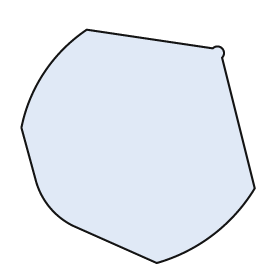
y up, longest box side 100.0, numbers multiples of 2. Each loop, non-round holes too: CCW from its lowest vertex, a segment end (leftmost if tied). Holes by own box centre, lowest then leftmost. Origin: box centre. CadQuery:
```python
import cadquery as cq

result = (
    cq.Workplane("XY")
    .moveTo(8.0, -50.0)
    .threePointArc((32.0, -38.0), (50.0, -18.0))
    .lineTo(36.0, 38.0)
    .threePointArc((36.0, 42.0), (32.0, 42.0))
    .lineTo(-22.0, 50.0)
    .threePointArc((-40.0, 32.0), (-50.0, 8.0))
    .lineTo(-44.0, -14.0)
    .threePointArc((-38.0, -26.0), (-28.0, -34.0))
    .close()
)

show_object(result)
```